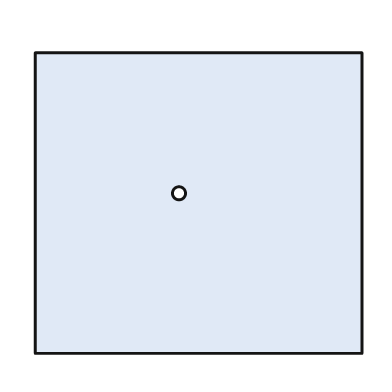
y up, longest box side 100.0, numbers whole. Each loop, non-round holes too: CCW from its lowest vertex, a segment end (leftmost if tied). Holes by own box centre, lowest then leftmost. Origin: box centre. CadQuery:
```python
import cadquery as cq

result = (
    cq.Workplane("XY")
    .moveTo(-50.0, -46.0)
    .lineTo(50.0, -46.0)
    .lineTo(50.0, 46.0)
    .lineTo(-50.0, 46.0)
    .close()
    .moveTo(-6.0, 3.0)
    .circle(2.0)
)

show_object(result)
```